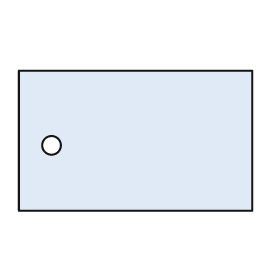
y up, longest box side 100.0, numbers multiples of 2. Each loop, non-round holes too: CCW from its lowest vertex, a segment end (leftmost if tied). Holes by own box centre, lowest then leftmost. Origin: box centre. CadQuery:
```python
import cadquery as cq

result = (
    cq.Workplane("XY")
    .moveTo(-50.0, -30.0)
    .lineTo(50.0, -30.0)
    .lineTo(50.0, 30.0)
    .lineTo(-50.0, 30.0)
    .close()
    .moveTo(-36.0, -2.0)
    .circle(4.0)
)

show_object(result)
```